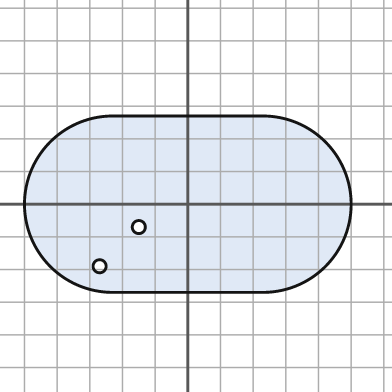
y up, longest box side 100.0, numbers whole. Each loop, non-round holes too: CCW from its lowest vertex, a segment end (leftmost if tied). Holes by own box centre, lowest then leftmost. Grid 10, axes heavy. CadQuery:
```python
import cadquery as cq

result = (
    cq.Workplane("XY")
    .moveTo(-23.0, -27.0)
    .lineTo(23.0, -27.0)
    .threePointArc((50.0, 0.0), (23.0, 27.0))
    .lineTo(-23.0, 27.0)
    .threePointArc((-50.0, 0.0), (-23.0, -27.0))
    .close()
    .moveTo(-27.0, -19.0)
    .circle(2.0)
    .moveTo(-15.0, -7.0)
    .circle(2.0)
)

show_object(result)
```